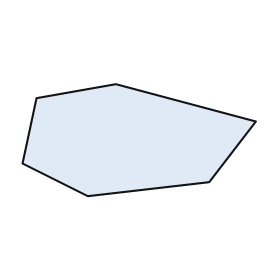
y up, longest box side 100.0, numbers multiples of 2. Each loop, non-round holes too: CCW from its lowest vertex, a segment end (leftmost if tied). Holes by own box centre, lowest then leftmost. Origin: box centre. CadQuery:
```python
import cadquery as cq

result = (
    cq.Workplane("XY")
    .moveTo(-22.0, -24.0)
    .lineTo(30.0, -18.0)
    .lineTo(50.0, 8.0)
    .lineTo(-10.0, 24.0)
    .lineTo(-44.0, 18.0)
    .lineTo(-50.0, -10.0)
    .close()
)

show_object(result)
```